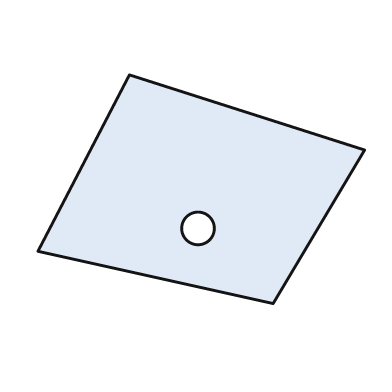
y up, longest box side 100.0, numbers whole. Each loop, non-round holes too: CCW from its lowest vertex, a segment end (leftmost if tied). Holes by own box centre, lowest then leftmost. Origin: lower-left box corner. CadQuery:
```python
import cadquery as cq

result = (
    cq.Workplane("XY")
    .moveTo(72.0, 0.0)
    .lineTo(100.0, 47.0)
    .lineTo(28.0, 70.0)
    .lineTo(0.0, 16.0)
    .close()
    .moveTo(49.0, 23.0)
    .circle(5.0)
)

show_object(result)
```